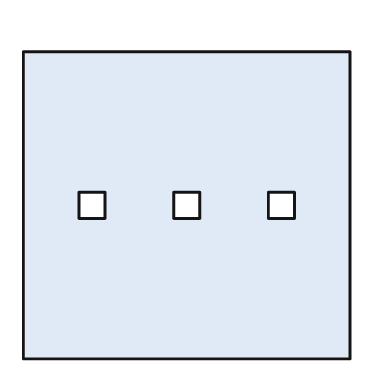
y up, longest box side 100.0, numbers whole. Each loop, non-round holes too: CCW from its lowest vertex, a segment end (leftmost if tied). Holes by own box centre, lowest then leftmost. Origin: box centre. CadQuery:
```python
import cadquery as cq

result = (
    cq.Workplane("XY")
    .moveTo(-50.0, -47.0)
    .lineTo(50.0, -47.0)
    .lineTo(50.0, 47.0)
    .lineTo(-50.0, 47.0)
    .close()
    .moveTo(-33.0, -4.0)
    .lineTo(-25.0, -4.0)
    .lineTo(-25.0, 4.0)
    .lineTo(-33.0, 4.0)
    .close()
    .moveTo(-4.0, -4.0)
    .lineTo(4.0, -4.0)
    .lineTo(4.0, 4.0)
    .lineTo(-4.0, 4.0)
    .close()
    .moveTo(25.0, -4.0)
    .lineTo(33.0, -4.0)
    .lineTo(33.0, 4.0)
    .lineTo(25.0, 4.0)
    .close()
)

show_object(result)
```